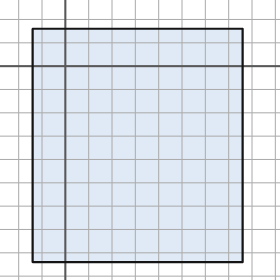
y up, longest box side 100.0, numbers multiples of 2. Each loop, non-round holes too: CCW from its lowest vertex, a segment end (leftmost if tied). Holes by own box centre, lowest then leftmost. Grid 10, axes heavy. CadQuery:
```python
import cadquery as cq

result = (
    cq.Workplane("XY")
    .moveTo(-14.0, -84.0)
    .lineTo(76.0, -84.0)
    .lineTo(76.0, 16.0)
    .lineTo(-14.0, 16.0)
    .close()
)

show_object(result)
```